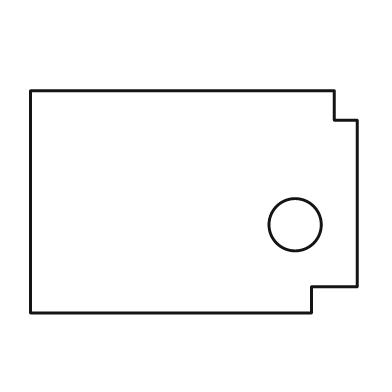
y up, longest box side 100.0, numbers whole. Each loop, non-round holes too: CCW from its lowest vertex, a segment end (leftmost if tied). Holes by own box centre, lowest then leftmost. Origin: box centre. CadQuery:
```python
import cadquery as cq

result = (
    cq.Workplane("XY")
    .moveTo(-50.0, -34.0)
    .lineTo(36.0, -34.0)
    .lineTo(36.0, -26.0)
    .lineTo(50.0, -26.0)
    .lineTo(50.0, 25.0)
    .lineTo(43.0, 25.0)
    .lineTo(43.0, 34.0)
    .lineTo(-50.0, 34.0)
    .close()
    .moveTo(31.0, -7.0)
    .circle(8.0)
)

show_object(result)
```